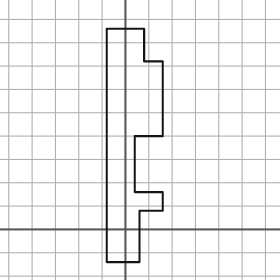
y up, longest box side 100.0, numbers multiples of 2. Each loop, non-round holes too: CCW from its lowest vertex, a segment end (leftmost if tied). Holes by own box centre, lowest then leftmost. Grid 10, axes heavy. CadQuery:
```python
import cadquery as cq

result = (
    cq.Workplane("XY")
    .moveTo(-8.0, -14.0)
    .lineTo(6.0, -14.0)
    .lineTo(6.0, 8.0)
    .lineTo(16.0, 8.0)
    .lineTo(16.0, 16.0)
    .lineTo(4.0, 16.0)
    .lineTo(4.0, 40.0)
    .lineTo(16.0, 40.0)
    .lineTo(16.0, 72.0)
    .lineTo(8.0, 72.0)
    .lineTo(8.0, 86.0)
    .lineTo(-8.0, 86.0)
    .close()
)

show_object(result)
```